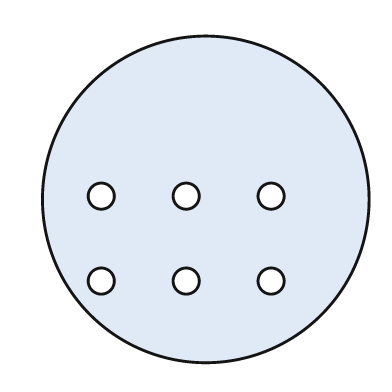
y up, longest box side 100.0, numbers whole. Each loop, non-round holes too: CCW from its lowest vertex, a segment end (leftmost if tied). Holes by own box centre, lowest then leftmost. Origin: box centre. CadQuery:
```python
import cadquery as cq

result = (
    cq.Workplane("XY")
    .moveTo(0.0, 0.0)
    .circle(50.0)
    .moveTo(-32.0, -25.0)
    .circle(4.0)
    .moveTo(-6.0, -25.0)
    .circle(4.0)
    .moveTo(20.0, -25.0)
    .circle(4.0)
    .moveTo(-32.0, 1.0)
    .circle(4.0)
    .moveTo(-6.0, 1.0)
    .circle(4.0)
    .moveTo(20.0, 1.0)
    .circle(4.0)
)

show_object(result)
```